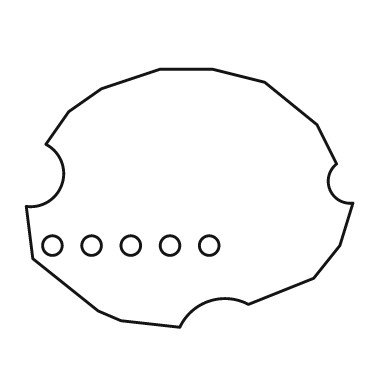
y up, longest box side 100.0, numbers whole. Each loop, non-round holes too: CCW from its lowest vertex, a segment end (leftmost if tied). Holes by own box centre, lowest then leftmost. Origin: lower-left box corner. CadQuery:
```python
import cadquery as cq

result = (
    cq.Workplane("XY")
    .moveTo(47.0, 0.0)
    .threePointArc((56.0, 8.0), (68.0, 7.0))
    .lineTo(88.0, 15.0)
    .lineTo(96.0, 25.0)
    .lineTo(100.0, 38.0)
    .threePointArc((93.0, 42.0), (95.0, 50.0))
    .lineTo(89.0, 62.0)
    .lineTo(73.0, 75.0)
    .lineTo(57.0, 79.0)
    .lineTo(41.0, 79.0)
    .lineTo(23.0, 73.0)
    .lineTo(13.0, 66.0)
    .lineTo(6.0, 56.0)
    .threePointArc((11.0, 44.0), (0.0, 37.0))
    .lineTo(2.0, 21.0)
    .lineTo(22.0, 5.0)
    .lineTo(29.0, 2.0)
    .close()
    .moveTo(8.0, 25.0)
    .circle(3.0)
    .moveTo(20.0, 25.0)
    .circle(3.0)
    .moveTo(32.0, 25.0)
    .circle(3.0)
    .moveTo(44.0, 25.0)
    .circle(3.0)
    .moveTo(56.0, 25.0)
    .circle(3.0)
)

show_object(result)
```